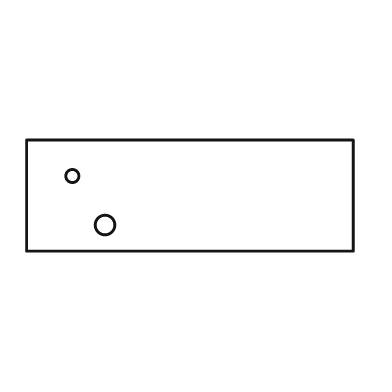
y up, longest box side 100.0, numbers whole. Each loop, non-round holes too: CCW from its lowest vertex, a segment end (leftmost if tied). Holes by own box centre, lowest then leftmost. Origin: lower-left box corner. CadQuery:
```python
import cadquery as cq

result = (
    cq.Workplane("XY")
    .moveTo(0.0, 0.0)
    .lineTo(100.0, 0.0)
    .lineTo(100.0, 34.0)
    .lineTo(0.0, 34.0)
    .close()
    .moveTo(24.0, 8.0)
    .circle(3.0)
    .moveTo(14.0, 23.0)
    .circle(2.0)
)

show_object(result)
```